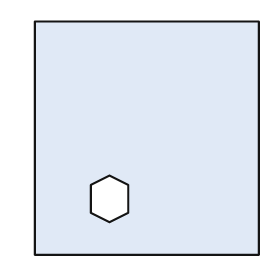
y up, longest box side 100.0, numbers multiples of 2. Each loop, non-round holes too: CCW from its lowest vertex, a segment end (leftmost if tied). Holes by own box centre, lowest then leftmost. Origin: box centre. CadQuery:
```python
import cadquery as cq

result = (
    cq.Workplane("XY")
    .moveTo(-48.0, -50.0)
    .lineTo(48.0, -50.0)
    .lineTo(48.0, 50.0)
    .lineTo(-48.0, 50.0)
    .close()
    .moveTo(-16.0, -36.0)
    .lineTo(-8.0, -32.0)
    .lineTo(-8.0, -20.0)
    .lineTo(-16.0, -16.0)
    .lineTo(-24.0, -20.0)
    .lineTo(-24.0, -32.0)
    .close()
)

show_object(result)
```